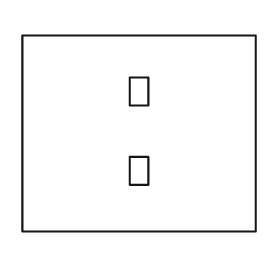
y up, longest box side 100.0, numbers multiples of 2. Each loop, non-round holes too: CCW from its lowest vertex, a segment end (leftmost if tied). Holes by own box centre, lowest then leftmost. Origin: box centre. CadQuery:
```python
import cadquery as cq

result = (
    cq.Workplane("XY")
    .moveTo(-50.0, -42.0)
    .lineTo(50.0, -42.0)
    .lineTo(50.0, 42.0)
    .lineTo(-50.0, 42.0)
    .close()
    .moveTo(-4.0, -22.0)
    .lineTo(4.0, -22.0)
    .lineTo(4.0, -10.0)
    .lineTo(-4.0, -10.0)
    .close()
    .moveTo(-4.0, 12.0)
    .lineTo(4.0, 12.0)
    .lineTo(4.0, 24.0)
    .lineTo(-4.0, 24.0)
    .close()
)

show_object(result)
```